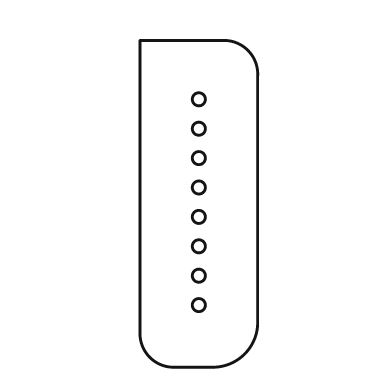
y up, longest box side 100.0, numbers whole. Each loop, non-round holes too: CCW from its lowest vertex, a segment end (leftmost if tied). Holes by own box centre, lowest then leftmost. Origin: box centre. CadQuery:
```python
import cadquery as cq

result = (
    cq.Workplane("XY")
    .moveTo(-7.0, -50.0)
    .lineTo(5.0, -50.0)
    .threePointArc((14.0, -46.0), (18.0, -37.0))
    .lineTo(18.0, 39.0)
    .threePointArc((15.0, 47.0), (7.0, 50.0))
    .lineTo(-18.0, 50.0)
    .lineTo(-18.0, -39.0)
    .threePointArc((-15.0, -47.0), (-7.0, -50.0))
    .close()
    .moveTo(0.0, -31.0)
    .circle(2.0)
    .moveTo(0.0, -22.0)
    .circle(2.0)
    .moveTo(0.0, -13.0)
    .circle(2.0)
    .moveTo(0.0, -4.0)
    .circle(2.0)
    .moveTo(0.0, 5.0)
    .circle(2.0)
    .moveTo(0.0, 14.0)
    .circle(2.0)
    .moveTo(0.0, 23.0)
    .circle(2.0)
    .moveTo(0.0, 32.0)
    .circle(2.0)
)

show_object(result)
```